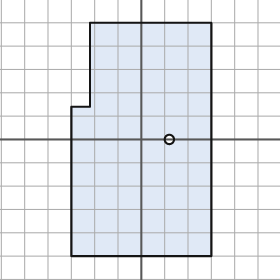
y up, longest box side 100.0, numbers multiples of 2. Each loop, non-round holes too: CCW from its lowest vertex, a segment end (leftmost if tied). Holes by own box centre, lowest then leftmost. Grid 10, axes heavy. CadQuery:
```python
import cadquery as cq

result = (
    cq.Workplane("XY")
    .moveTo(-30.0, -50.0)
    .lineTo(30.0, -50.0)
    .lineTo(30.0, 50.0)
    .lineTo(-22.0, 50.0)
    .lineTo(-22.0, 14.0)
    .lineTo(-30.0, 14.0)
    .close()
    .moveTo(12.0, 0.0)
    .circle(2.0)
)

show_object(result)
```